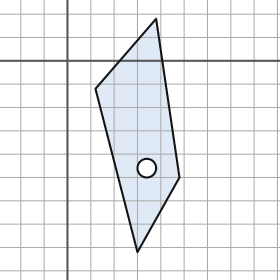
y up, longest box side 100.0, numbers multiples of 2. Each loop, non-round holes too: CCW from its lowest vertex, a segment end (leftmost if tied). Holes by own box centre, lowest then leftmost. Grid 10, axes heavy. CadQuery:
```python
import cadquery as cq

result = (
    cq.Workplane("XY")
    .moveTo(30.0, -82.0)
    .lineTo(48.0, -50.0)
    .lineTo(38.0, 18.0)
    .lineTo(12.0, -12.0)
    .close()
    .moveTo(34.0, -46.0)
    .circle(4.0)
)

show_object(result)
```